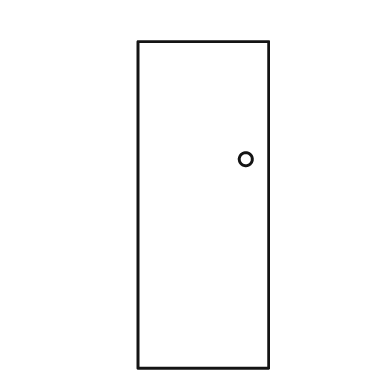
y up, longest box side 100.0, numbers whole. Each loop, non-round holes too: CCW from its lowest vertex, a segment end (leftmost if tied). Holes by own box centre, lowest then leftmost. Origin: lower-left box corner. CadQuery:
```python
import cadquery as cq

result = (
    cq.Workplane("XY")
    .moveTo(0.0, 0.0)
    .lineTo(40.0, 0.0)
    .lineTo(40.0, 100.0)
    .lineTo(0.0, 100.0)
    .close()
    .moveTo(33.0, 64.0)
    .circle(2.0)
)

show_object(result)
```